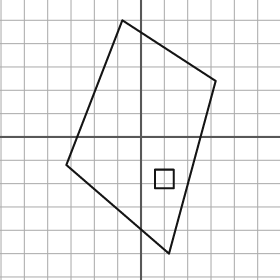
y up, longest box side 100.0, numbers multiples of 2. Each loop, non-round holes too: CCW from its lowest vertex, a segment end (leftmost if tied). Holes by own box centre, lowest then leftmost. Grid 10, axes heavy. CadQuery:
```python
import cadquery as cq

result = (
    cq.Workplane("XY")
    .moveTo(12.0, -50.0)
    .lineTo(32.0, 24.0)
    .lineTo(-8.0, 50.0)
    .lineTo(-32.0, -12.0)
    .close()
    .moveTo(6.0, -22.0)
    .lineTo(14.0, -22.0)
    .lineTo(14.0, -14.0)
    .lineTo(6.0, -14.0)
    .close()
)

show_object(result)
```